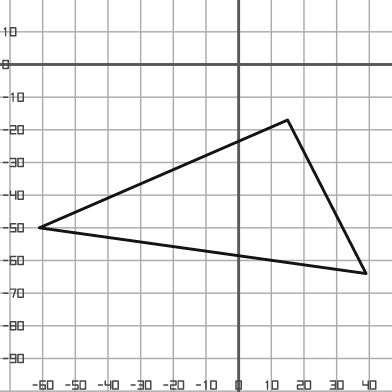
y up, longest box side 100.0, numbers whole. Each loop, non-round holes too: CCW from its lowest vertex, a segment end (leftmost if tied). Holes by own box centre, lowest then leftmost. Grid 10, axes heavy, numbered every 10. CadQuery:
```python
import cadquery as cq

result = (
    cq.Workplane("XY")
    .moveTo(39.0, -64.0)
    .lineTo(15.0, -17.0)
    .lineTo(-61.0, -50.0)
    .close()
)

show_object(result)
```